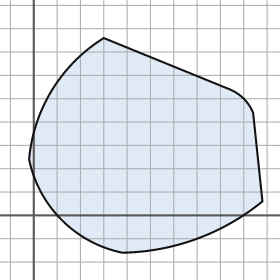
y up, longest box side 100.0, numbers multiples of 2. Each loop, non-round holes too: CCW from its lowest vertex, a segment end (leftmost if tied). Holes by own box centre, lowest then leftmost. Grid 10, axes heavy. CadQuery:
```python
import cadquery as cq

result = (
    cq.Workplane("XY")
    .moveTo(38.0, -16.0)
    .threePointArc((70.0, -10.0), (98.0, 6.0))
    .lineTo(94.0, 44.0)
    .threePointArc((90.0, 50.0), (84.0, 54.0))
    .lineTo(30.0, 76.0)
    .threePointArc((8.0, 54.0), (-2.0, 24.0))
    .threePointArc((12.0, -2.0), (38.0, -16.0))
    .close()
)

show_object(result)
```